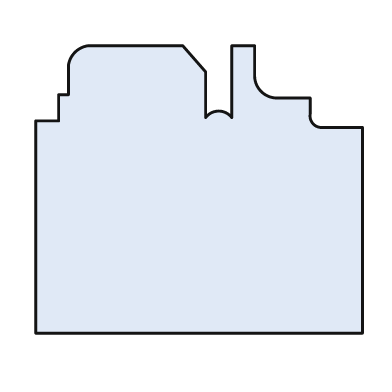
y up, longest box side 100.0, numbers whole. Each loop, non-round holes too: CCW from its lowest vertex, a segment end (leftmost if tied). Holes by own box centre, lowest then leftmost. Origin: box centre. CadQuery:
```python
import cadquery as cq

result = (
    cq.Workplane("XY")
    .moveTo(-50.0, -44.0)
    .lineTo(50.0, -44.0)
    .lineTo(50.0, 19.0)
    .lineTo(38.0, 19.0)
    .threePointArc((35.0, 20.0), (34.0, 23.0))
    .lineTo(34.0, 28.0)
    .lineTo(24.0, 28.0)
    .threePointArc((19.0, 30.0), (17.0, 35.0))
    .lineTo(17.0, 44.0)
    .lineTo(10.0, 44.0)
    .lineTo(10.0, 22.0)
    .threePointArc((6.0, 24.0), (2.0, 22.0))
    .lineTo(2.0, 36.0)
    .lineTo(-5.0, 44.0)
    .lineTo(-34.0, 44.0)
    .threePointArc((-38.0, 42.0), (-40.0, 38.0))
    .lineTo(-40.0, 29.0)
    .lineTo(-43.0, 29.0)
    .lineTo(-43.0, 21.0)
    .lineTo(-50.0, 21.0)
    .close()
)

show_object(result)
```